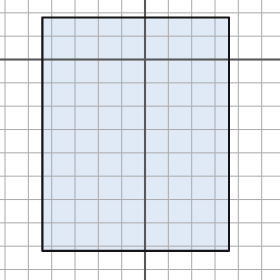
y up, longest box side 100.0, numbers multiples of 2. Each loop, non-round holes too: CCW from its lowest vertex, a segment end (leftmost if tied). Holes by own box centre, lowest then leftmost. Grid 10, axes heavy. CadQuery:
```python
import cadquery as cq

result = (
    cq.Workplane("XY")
    .moveTo(-44.0, -82.0)
    .lineTo(36.0, -82.0)
    .lineTo(36.0, 18.0)
    .lineTo(-44.0, 18.0)
    .close()
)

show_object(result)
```